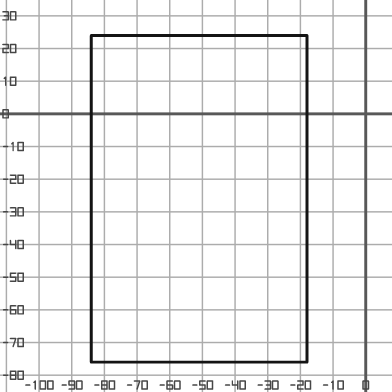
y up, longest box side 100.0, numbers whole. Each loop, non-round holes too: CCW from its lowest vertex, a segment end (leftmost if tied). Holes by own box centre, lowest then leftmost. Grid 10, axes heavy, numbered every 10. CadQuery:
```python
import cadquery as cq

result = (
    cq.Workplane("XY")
    .moveTo(-84.0, -76.0)
    .lineTo(-18.0, -76.0)
    .lineTo(-18.0, 24.0)
    .lineTo(-84.0, 24.0)
    .close()
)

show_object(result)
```